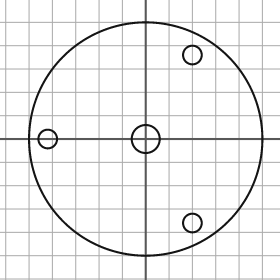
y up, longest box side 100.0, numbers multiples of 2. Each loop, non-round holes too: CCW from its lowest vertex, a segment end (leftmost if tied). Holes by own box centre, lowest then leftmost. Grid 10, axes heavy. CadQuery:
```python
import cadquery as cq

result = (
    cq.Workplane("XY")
    .moveTo(0.0, 0.0)
    .circle(50.0)
    .moveTo(20.0, -36.0)
    .circle(4.0)
    .moveTo(-42.0, 0.0)
    .circle(4.0)
    .moveTo(0.0, 0.0)
    .circle(6.0)
    .moveTo(20.0, 36.0)
    .circle(4.0)
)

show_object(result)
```